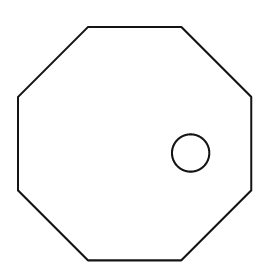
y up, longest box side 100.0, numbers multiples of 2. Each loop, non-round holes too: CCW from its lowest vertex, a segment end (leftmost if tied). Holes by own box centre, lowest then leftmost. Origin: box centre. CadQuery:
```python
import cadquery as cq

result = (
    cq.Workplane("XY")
    .moveTo(-20.0, -50.0)
    .lineTo(20.0, -50.0)
    .lineTo(50.0, -20.0)
    .lineTo(50.0, 20.0)
    .lineTo(20.0, 50.0)
    .lineTo(-20.0, 50.0)
    .lineTo(-50.0, 20.0)
    .lineTo(-50.0, -20.0)
    .close()
    .moveTo(24.0, -4.0)
    .circle(8.0)
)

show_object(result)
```